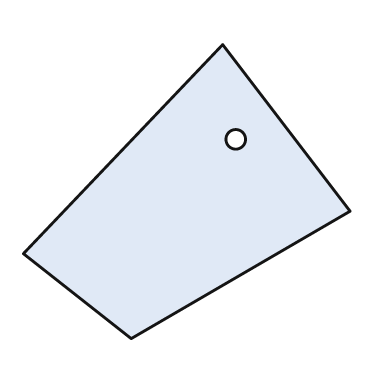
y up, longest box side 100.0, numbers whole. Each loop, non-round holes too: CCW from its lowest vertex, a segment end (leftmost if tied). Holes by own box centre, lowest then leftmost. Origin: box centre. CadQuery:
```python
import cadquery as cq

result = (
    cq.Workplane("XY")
    .moveTo(-17.0, -45.0)
    .lineTo(50.0, -6.0)
    .lineTo(11.0, 45.0)
    .lineTo(-50.0, -19.0)
    .close()
    .moveTo(15.0, 16.0)
    .circle(3.0)
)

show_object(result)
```